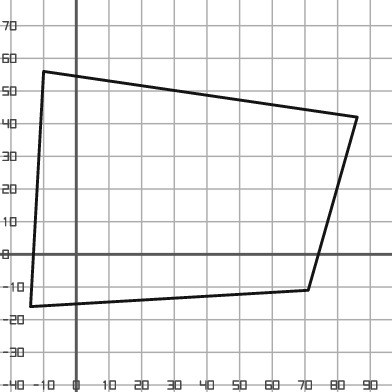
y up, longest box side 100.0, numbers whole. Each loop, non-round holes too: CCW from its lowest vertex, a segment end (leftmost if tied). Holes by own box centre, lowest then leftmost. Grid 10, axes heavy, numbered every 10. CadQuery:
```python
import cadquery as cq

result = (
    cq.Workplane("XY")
    .moveTo(-14.0, -16.0)
    .lineTo(71.0, -11.0)
    .lineTo(86.0, 42.0)
    .lineTo(-10.0, 56.0)
    .close()
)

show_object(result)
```